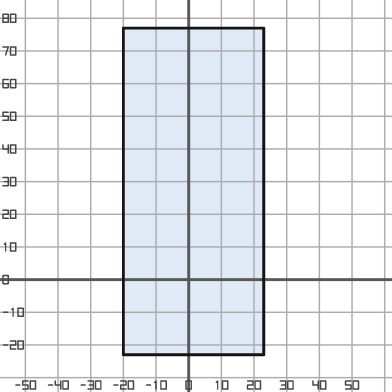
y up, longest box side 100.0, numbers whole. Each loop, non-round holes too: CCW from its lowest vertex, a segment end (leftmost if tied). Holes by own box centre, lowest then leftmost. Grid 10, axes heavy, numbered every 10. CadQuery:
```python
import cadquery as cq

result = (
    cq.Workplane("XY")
    .moveTo(-20.0, -23.0)
    .lineTo(23.0, -23.0)
    .lineTo(23.0, 77.0)
    .lineTo(-20.0, 77.0)
    .close()
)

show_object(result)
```